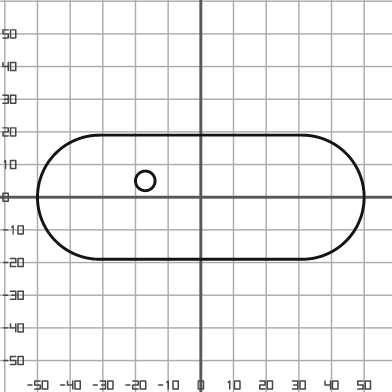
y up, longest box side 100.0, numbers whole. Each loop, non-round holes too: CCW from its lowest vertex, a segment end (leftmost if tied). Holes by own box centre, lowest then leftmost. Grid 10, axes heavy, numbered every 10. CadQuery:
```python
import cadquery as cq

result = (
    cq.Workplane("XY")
    .moveTo(-31.0, -19.0)
    .lineTo(31.0, -19.0)
    .threePointArc((50.0, 0.0), (31.0, 19.0))
    .lineTo(-31.0, 19.0)
    .threePointArc((-50.0, 0.0), (-31.0, -19.0))
    .close()
    .moveTo(-17.0, 5.0)
    .circle(3.0)
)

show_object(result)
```